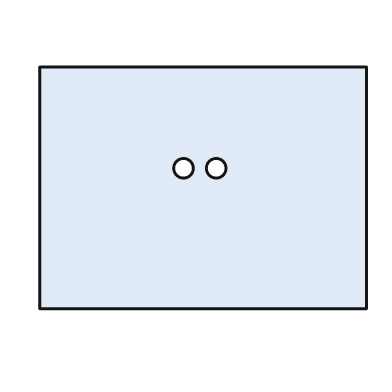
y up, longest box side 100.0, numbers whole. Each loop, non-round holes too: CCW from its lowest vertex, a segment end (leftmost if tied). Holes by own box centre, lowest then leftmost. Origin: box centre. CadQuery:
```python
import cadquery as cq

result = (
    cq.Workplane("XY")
    .moveTo(-50.0, -37.0)
    .lineTo(50.0, -37.0)
    .lineTo(50.0, 37.0)
    .lineTo(-50.0, 37.0)
    .close()
    .moveTo(-6.0, 6.0)
    .circle(3.0)
    .moveTo(4.0, 6.0)
    .circle(3.0)
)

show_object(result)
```